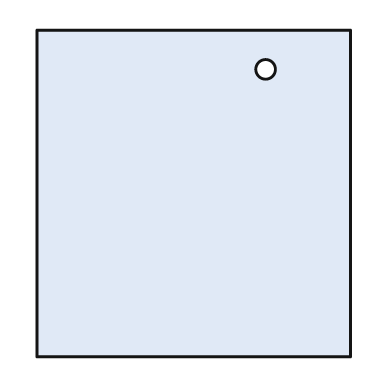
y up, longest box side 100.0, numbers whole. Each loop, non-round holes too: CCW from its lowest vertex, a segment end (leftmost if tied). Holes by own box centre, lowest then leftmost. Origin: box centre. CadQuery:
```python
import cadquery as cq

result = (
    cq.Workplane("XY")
    .moveTo(-48.0, -50.0)
    .lineTo(48.0, -50.0)
    .lineTo(48.0, 50.0)
    .lineTo(-48.0, 50.0)
    .close()
    .moveTo(22.0, 38.0)
    .circle(3.0)
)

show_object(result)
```